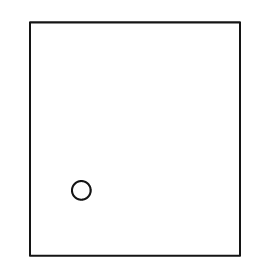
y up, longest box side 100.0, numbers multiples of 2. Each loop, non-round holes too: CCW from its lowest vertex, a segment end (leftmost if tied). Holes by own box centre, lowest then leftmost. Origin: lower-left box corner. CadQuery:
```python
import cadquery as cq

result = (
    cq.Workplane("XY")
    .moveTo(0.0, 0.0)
    .lineTo(90.0, 0.0)
    .lineTo(90.0, 100.0)
    .lineTo(0.0, 100.0)
    .close()
    .moveTo(22.0, 28.0)
    .circle(4.0)
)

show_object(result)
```